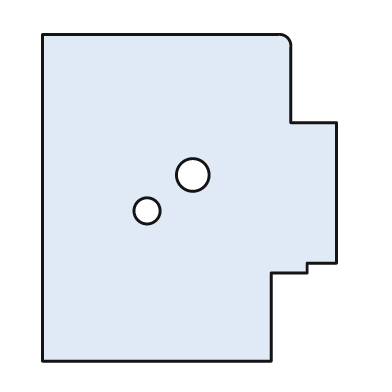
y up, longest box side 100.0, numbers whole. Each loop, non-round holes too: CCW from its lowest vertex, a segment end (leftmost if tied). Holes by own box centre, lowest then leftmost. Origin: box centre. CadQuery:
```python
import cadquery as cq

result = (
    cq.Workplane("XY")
    .moveTo(-45.0, -50.0)
    .lineTo(25.0, -50.0)
    .lineTo(25.0, -23.0)
    .lineTo(36.0, -23.0)
    .lineTo(36.0, -20.0)
    .lineTo(45.0, -20.0)
    .lineTo(45.0, 23.0)
    .lineTo(31.0, 23.0)
    .lineTo(31.0, 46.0)
    .threePointArc((30.0, 49.0), (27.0, 50.0))
    .lineTo(-45.0, 50.0)
    .close()
    .moveTo(-13.0, -4.0)
    .circle(4.0)
    .moveTo(1.0, 7.0)
    .circle(5.0)
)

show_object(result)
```